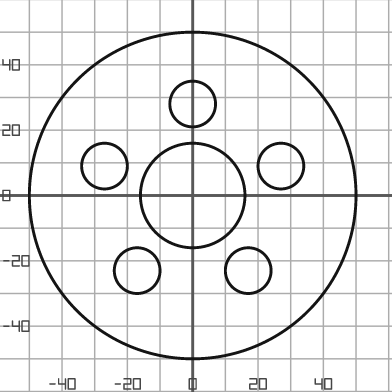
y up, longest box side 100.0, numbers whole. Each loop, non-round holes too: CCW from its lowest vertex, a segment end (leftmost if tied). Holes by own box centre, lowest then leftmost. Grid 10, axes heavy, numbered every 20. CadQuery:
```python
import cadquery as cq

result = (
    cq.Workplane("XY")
    .moveTo(0.0, 0.0)
    .circle(50.0)
    .moveTo(-17.0, -23.0)
    .circle(7.0)
    .moveTo(17.0, -23.0)
    .circle(7.0)
    .moveTo(0.0, 0.0)
    .circle(16.0)
    .moveTo(-27.0, 9.0)
    .circle(7.0)
    .moveTo(27.0, 9.0)
    .circle(7.0)
    .moveTo(0.0, 28.0)
    .circle(7.0)
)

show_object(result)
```